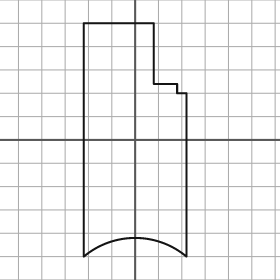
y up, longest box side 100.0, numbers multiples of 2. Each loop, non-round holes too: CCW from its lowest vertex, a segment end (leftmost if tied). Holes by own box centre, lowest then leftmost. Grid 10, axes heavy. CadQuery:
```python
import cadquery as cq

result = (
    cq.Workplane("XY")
    .moveTo(-22.0, -50.0)
    .threePointArc((0.0, -42.0), (22.0, -50.0))
    .lineTo(22.0, 20.0)
    .lineTo(18.0, 20.0)
    .lineTo(18.0, 24.0)
    .lineTo(8.0, 24.0)
    .lineTo(8.0, 50.0)
    .lineTo(-22.0, 50.0)
    .close()
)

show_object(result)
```